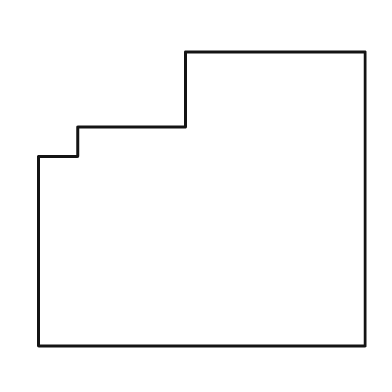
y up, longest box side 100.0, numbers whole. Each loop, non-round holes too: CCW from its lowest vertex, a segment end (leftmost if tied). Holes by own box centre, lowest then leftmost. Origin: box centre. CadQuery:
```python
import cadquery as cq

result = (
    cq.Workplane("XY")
    .moveTo(-50.0, -45.0)
    .lineTo(50.0, -45.0)
    .lineTo(50.0, 45.0)
    .lineTo(-5.0, 45.0)
    .lineTo(-5.0, 22.0)
    .lineTo(-38.0, 22.0)
    .lineTo(-38.0, 13.0)
    .lineTo(-50.0, 13.0)
    .close()
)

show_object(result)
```